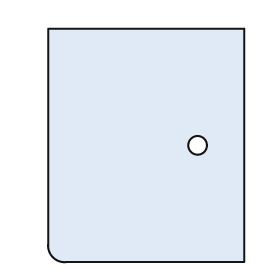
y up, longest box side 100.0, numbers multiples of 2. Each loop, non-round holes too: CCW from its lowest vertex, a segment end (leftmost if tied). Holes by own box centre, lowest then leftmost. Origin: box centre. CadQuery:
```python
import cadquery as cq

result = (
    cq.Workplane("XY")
    .moveTo(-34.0, -50.0)
    .lineTo(42.0, -50.0)
    .lineTo(42.0, 50.0)
    .lineTo(-42.0, 50.0)
    .lineTo(-42.0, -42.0)
    .threePointArc((-40.0, -48.0), (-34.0, -50.0))
    .close()
    .moveTo(22.0, 0.0)
    .circle(4.0)
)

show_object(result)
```